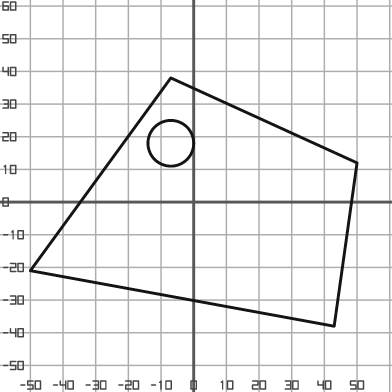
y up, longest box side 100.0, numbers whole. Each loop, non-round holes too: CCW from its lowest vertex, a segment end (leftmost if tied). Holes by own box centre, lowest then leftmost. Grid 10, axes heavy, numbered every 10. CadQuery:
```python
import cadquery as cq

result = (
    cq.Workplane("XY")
    .moveTo(43.0, -38.0)
    .lineTo(50.0, 12.0)
    .lineTo(-7.0, 38.0)
    .lineTo(-50.0, -21.0)
    .close()
    .moveTo(-7.0, 18.0)
    .circle(7.0)
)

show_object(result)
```